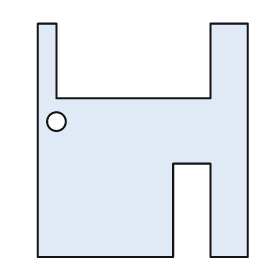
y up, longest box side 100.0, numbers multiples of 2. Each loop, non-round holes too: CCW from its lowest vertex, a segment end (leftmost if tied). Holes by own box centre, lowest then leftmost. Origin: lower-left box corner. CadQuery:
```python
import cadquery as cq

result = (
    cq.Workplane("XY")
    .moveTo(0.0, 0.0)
    .lineTo(58.0, 0.0)
    .lineTo(58.0, 40.0)
    .lineTo(74.0, 40.0)
    .lineTo(74.0, 0.0)
    .lineTo(90.0, 0.0)
    .lineTo(90.0, 100.0)
    .lineTo(74.0, 100.0)
    .lineTo(74.0, 68.0)
    .lineTo(8.0, 68.0)
    .lineTo(8.0, 100.0)
    .lineTo(0.0, 100.0)
    .close()
    .moveTo(8.0, 58.0)
    .circle(4.0)
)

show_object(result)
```